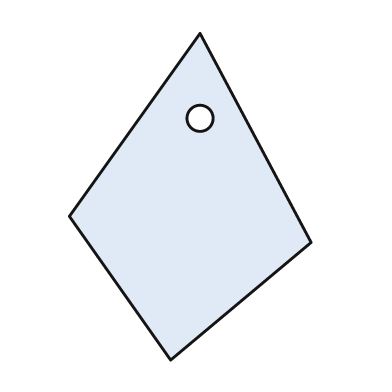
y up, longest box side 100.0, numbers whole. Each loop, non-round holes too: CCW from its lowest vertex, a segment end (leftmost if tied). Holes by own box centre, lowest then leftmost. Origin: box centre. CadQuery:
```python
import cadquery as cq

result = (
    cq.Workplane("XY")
    .moveTo(-6.0, -50.0)
    .lineTo(37.0, -14.0)
    .lineTo(3.0, 50.0)
    .lineTo(-37.0, -6.0)
    .close()
    .moveTo(3.0, 24.0)
    .circle(4.0)
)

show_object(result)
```